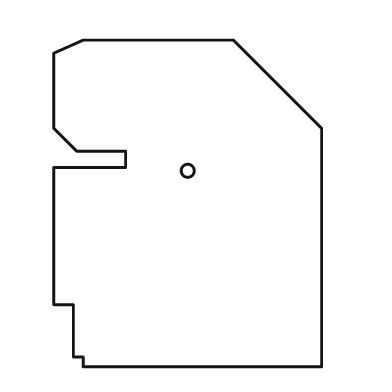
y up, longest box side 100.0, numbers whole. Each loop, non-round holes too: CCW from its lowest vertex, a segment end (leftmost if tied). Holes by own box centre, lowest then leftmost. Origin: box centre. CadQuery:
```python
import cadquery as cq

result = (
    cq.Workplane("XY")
    .moveTo(-32.0, -50.0)
    .lineTo(41.0, -50.0)
    .lineTo(41.0, 23.0)
    .lineTo(14.0, 50.0)
    .lineTo(-32.0, 50.0)
    .lineTo(-41.0, 46.0)
    .lineTo(-41.0, 23.0)
    .lineTo(-34.0, 16.0)
    .lineTo(-19.0, 16.0)
    .lineTo(-19.0, 11.0)
    .lineTo(-41.0, 11.0)
    .lineTo(-41.0, -31.0)
    .lineTo(-35.0, -31.0)
    .lineTo(-35.0, -47.0)
    .lineTo(-32.0, -47.0)
    .close()
    .moveTo(0.0, 10.0)
    .circle(2.0)
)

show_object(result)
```